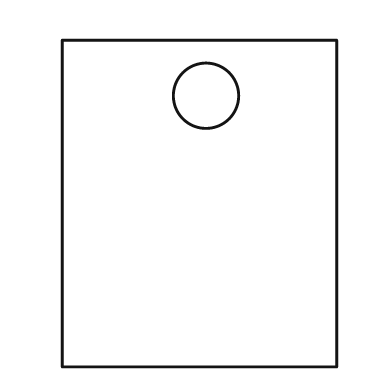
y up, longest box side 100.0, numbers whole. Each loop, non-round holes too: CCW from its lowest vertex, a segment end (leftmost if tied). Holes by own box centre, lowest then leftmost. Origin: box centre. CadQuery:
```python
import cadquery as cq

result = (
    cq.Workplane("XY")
    .moveTo(-42.0, -50.0)
    .lineTo(42.0, -50.0)
    .lineTo(42.0, 50.0)
    .lineTo(-42.0, 50.0)
    .close()
    .moveTo(2.0, 33.0)
    .circle(10.0)
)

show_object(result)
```